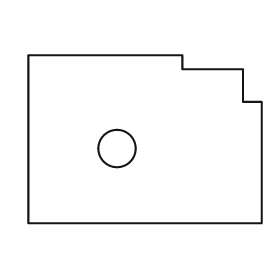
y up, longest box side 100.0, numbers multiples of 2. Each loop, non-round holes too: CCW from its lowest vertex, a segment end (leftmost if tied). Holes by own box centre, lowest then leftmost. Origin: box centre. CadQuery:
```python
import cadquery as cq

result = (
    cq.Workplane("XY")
    .moveTo(-50.0, -36.0)
    .lineTo(50.0, -36.0)
    .lineTo(50.0, 16.0)
    .lineTo(42.0, 16.0)
    .lineTo(42.0, 30.0)
    .lineTo(16.0, 30.0)
    .lineTo(16.0, 36.0)
    .lineTo(-50.0, 36.0)
    .close()
    .moveTo(-12.0, -4.0)
    .circle(8.0)
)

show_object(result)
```